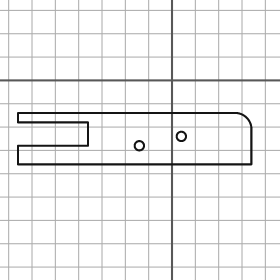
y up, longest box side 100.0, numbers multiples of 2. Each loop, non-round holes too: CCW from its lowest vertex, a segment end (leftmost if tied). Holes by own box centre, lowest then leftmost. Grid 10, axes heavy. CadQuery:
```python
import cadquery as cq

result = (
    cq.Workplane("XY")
    .moveTo(-66.0, -36.0)
    .lineTo(34.0, -36.0)
    .lineTo(34.0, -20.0)
    .threePointArc((32.0, -16.0), (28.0, -14.0))
    .lineTo(-66.0, -14.0)
    .lineTo(-66.0, -18.0)
    .lineTo(-36.0, -18.0)
    .lineTo(-36.0, -28.0)
    .lineTo(-66.0, -28.0)
    .close()
    .moveTo(-14.0, -28.0)
    .circle(2.0)
    .moveTo(4.0, -24.0)
    .circle(2.0)
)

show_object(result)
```